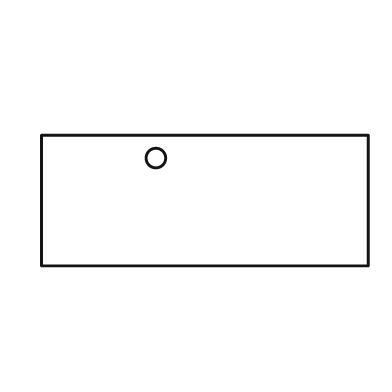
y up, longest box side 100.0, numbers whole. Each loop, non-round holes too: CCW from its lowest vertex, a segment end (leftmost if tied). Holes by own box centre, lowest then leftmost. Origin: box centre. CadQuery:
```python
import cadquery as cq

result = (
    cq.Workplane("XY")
    .moveTo(-50.0, -20.0)
    .lineTo(50.0, -20.0)
    .lineTo(50.0, 20.0)
    .lineTo(-50.0, 20.0)
    .close()
    .moveTo(-15.0, 13.0)
    .circle(3.0)
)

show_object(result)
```